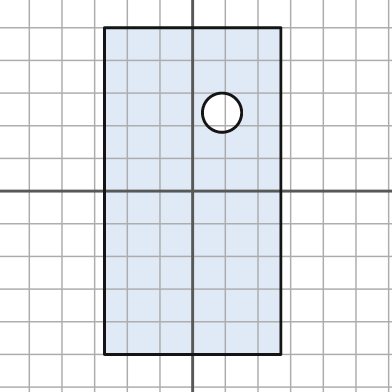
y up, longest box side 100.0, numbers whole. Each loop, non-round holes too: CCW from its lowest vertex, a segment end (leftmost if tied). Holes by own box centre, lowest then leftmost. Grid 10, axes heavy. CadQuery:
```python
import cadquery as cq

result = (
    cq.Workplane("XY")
    .moveTo(-27.0, -50.0)
    .lineTo(27.0, -50.0)
    .lineTo(27.0, 50.0)
    .lineTo(-27.0, 50.0)
    .close()
    .moveTo(9.0, 24.0)
    .circle(6.0)
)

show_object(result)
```